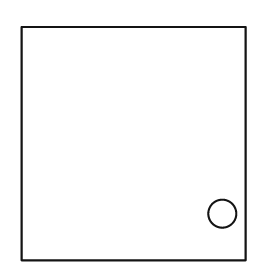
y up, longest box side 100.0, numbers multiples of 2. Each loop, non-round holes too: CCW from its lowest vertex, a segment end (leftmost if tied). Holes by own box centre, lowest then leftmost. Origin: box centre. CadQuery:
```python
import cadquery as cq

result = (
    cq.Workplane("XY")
    .moveTo(-48.0, -50.0)
    .lineTo(48.0, -50.0)
    .lineTo(48.0, 50.0)
    .lineTo(-48.0, 50.0)
    .close()
    .moveTo(38.0, -30.0)
    .circle(6.0)
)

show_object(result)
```